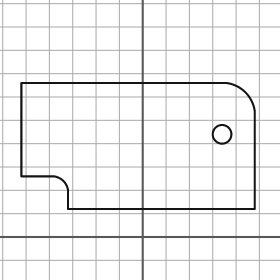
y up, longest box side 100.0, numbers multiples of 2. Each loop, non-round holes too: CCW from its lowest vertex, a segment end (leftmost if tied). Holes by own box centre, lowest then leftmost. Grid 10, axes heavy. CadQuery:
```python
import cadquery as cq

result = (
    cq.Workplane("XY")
    .moveTo(-32.0, 12.0)
    .lineTo(48.0, 12.0)
    .lineTo(48.0, 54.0)
    .threePointArc((44.0, 62.0), (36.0, 66.0))
    .lineTo(-52.0, 66.0)
    .lineTo(-52.0, 26.0)
    .lineTo(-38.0, 26.0)
    .threePointArc((-34.0, 24.0), (-32.0, 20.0))
    .close()
    .moveTo(34.0, 44.0)
    .circle(4.0)
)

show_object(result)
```